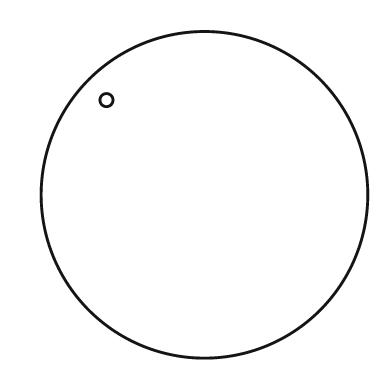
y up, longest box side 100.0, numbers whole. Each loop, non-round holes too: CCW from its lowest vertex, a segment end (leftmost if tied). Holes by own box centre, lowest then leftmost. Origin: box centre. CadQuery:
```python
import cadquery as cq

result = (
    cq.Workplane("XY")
    .moveTo(0.0, 0.0)
    .circle(50.0)
    .moveTo(-30.0, 29.0)
    .circle(2.0)
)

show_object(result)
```